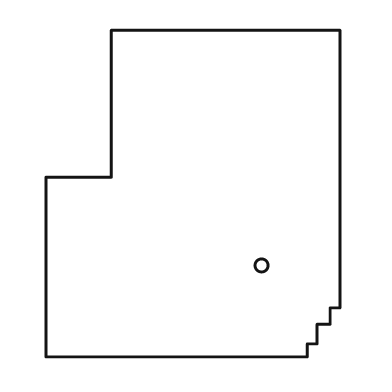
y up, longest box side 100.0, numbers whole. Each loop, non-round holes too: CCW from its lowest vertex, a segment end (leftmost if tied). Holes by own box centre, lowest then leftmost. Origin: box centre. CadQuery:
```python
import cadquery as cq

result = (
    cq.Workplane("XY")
    .moveTo(-45.0, -50.0)
    .lineTo(35.0, -50.0)
    .lineTo(35.0, -46.0)
    .lineTo(38.0, -46.0)
    .lineTo(38.0, -40.0)
    .lineTo(42.0, -40.0)
    .lineTo(42.0, -35.0)
    .lineTo(45.0, -35.0)
    .lineTo(45.0, 50.0)
    .lineTo(-25.0, 50.0)
    .lineTo(-25.0, 5.0)
    .lineTo(-45.0, 5.0)
    .close()
    .moveTo(21.0, -22.0)
    .circle(2.0)
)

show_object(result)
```